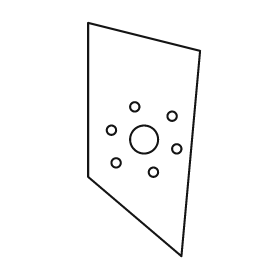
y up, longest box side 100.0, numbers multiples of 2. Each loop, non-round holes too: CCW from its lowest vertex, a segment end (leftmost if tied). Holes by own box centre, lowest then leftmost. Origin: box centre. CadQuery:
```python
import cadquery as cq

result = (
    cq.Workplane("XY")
    .moveTo(16.0, -50.0)
    .lineTo(24.0, 38.0)
    .lineTo(-24.0, 50.0)
    .lineTo(-24.0, -16.0)
    .close()
    .moveTo(4.0, -14.0)
    .circle(2.0)
    .moveTo(-12.0, -10.0)
    .circle(2.0)
    .moveTo(14.0, -4.0)
    .circle(2.0)
    .moveTo(0.0, 0.0)
    .circle(6.0)
    .moveTo(-14.0, 4.0)
    .circle(2.0)
    .moveTo(12.0, 10.0)
    .circle(2.0)
    .moveTo(-4.0, 14.0)
    .circle(2.0)
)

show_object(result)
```